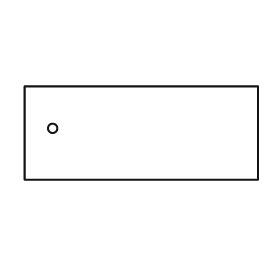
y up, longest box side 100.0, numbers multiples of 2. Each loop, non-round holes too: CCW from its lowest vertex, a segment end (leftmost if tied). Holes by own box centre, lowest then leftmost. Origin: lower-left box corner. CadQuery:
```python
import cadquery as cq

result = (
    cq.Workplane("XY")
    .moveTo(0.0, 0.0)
    .lineTo(100.0, 0.0)
    .lineTo(100.0, 40.0)
    .lineTo(0.0, 40.0)
    .close()
    .moveTo(12.0, 22.0)
    .circle(2.0)
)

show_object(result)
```